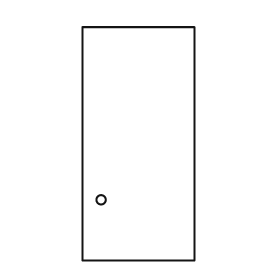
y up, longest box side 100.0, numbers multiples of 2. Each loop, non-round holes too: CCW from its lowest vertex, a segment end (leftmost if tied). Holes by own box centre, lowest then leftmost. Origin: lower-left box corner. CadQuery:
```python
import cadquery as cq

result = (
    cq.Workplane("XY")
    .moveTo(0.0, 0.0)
    .lineTo(48.0, 0.0)
    .lineTo(48.0, 100.0)
    .lineTo(0.0, 100.0)
    .close()
    .moveTo(8.0, 26.0)
    .circle(2.0)
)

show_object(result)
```